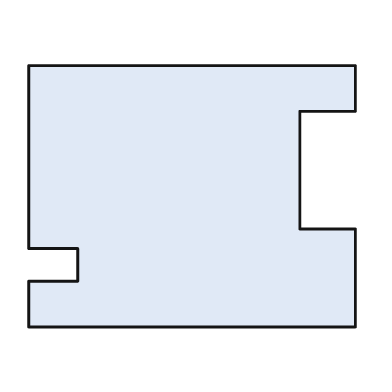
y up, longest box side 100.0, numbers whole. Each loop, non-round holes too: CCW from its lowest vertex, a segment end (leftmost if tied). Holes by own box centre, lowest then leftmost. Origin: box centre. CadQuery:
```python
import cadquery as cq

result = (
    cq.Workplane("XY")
    .moveTo(-50.0, -40.0)
    .lineTo(50.0, -40.0)
    .lineTo(50.0, -10.0)
    .lineTo(33.0, -10.0)
    .lineTo(33.0, 26.0)
    .lineTo(50.0, 26.0)
    .lineTo(50.0, 40.0)
    .lineTo(-50.0, 40.0)
    .lineTo(-50.0, -16.0)
    .lineTo(-35.0, -16.0)
    .lineTo(-35.0, -26.0)
    .lineTo(-50.0, -26.0)
    .close()
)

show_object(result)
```